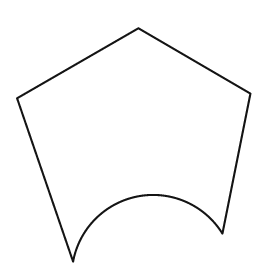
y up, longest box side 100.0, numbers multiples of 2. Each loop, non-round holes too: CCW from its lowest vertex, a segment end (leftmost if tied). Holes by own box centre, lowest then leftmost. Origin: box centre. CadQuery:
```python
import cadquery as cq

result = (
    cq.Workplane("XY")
    .moveTo(-26.0, -50.0)
    .threePointArc((2.0, -22.0), (38.0, -38.0))
    .lineTo(50.0, 22.0)
    .lineTo(2.0, 50.0)
    .lineTo(-50.0, 20.0)
    .close()
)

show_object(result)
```